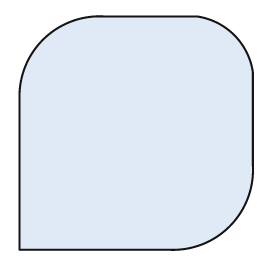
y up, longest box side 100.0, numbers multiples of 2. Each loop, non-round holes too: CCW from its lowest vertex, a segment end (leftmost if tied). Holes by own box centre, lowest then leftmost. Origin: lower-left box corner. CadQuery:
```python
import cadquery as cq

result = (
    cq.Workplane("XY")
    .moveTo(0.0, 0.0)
    .lineTo(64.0, 0.0)
    .threePointArc((90.0, 10.0), (100.0, 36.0))
    .lineTo(100.0, 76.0)
    .threePointArc((92.0, 92.0), (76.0, 100.0))
    .lineTo(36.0, 100.0)
    .threePointArc((10.0, 90.0), (0.0, 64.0))
    .close()
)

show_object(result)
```